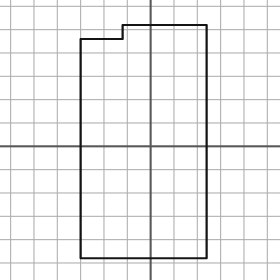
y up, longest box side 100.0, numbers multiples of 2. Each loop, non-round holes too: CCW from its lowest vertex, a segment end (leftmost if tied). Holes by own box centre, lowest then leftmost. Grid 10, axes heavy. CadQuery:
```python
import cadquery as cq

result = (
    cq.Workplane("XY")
    .moveTo(-30.0, -48.0)
    .lineTo(24.0, -48.0)
    .lineTo(24.0, 52.0)
    .lineTo(-12.0, 52.0)
    .lineTo(-12.0, 46.0)
    .lineTo(-30.0, 46.0)
    .close()
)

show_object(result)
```